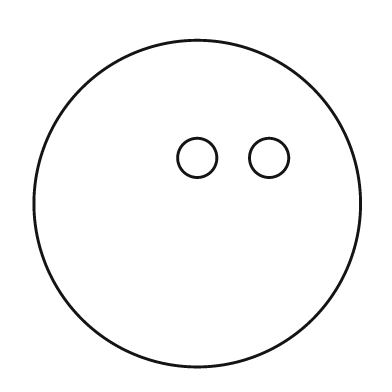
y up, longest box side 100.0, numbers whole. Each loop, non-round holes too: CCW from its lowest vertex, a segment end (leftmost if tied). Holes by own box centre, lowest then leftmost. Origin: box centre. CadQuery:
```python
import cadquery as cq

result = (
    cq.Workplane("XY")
    .moveTo(0.0, 0.0)
    .circle(50.0)
    .moveTo(0.0, 14.0)
    .circle(6.0)
    .moveTo(22.0, 14.0)
    .circle(6.0)
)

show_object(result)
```